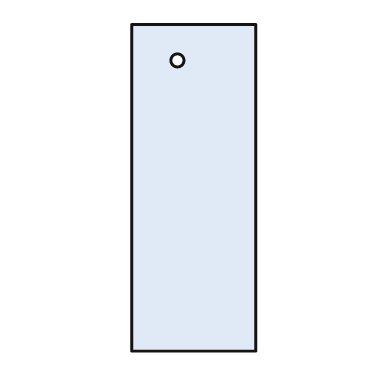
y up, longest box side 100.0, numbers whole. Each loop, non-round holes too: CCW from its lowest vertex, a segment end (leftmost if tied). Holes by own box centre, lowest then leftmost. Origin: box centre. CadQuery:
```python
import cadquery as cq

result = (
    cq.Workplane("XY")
    .moveTo(-19.0, -50.0)
    .lineTo(19.0, -50.0)
    .lineTo(19.0, 50.0)
    .lineTo(-19.0, 50.0)
    .close()
    .moveTo(-5.0, 39.0)
    .circle(2.0)
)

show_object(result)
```